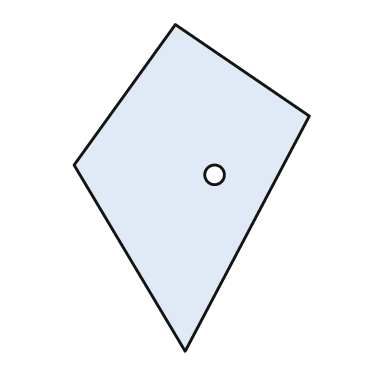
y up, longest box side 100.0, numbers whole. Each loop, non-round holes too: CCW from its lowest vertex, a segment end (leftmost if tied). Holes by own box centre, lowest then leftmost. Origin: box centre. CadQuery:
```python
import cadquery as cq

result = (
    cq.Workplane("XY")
    .moveTo(-2.0, -50.0)
    .lineTo(36.0, 22.0)
    .lineTo(-5.0, 50.0)
    .lineTo(-36.0, 7.0)
    .close()
    .moveTo(7.0, 4.0)
    .circle(3.0)
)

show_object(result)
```